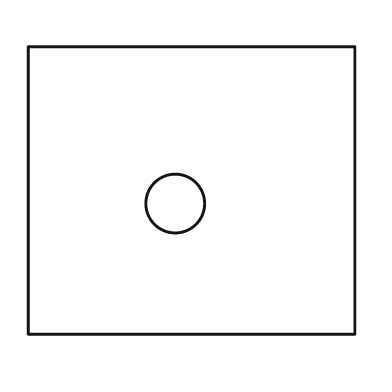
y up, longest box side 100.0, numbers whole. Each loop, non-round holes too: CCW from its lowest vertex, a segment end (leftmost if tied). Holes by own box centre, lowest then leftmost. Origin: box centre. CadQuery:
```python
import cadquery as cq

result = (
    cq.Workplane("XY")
    .moveTo(-50.0, -44.0)
    .lineTo(50.0, -44.0)
    .lineTo(50.0, 44.0)
    .lineTo(-50.0, 44.0)
    .close()
    .moveTo(-5.0, -4.0)
    .circle(9.0)
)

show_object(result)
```